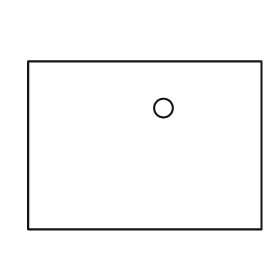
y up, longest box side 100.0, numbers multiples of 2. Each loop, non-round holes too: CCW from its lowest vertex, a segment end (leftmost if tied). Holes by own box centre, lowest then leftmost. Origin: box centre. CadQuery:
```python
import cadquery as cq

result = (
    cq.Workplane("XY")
    .moveTo(-50.0, -36.0)
    .lineTo(50.0, -36.0)
    .lineTo(50.0, 36.0)
    .lineTo(-50.0, 36.0)
    .close()
    .moveTo(8.0, 16.0)
    .circle(4.0)
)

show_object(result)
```